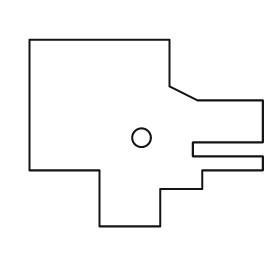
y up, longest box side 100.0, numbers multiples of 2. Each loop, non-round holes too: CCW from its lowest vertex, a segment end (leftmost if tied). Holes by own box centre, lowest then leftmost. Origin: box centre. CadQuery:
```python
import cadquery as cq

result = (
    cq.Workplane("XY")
    .moveTo(-20.0, -40.0)
    .lineTo(6.0, -40.0)
    .lineTo(6.0, -24.0)
    .lineTo(24.0, -24.0)
    .lineTo(24.0, -16.0)
    .lineTo(50.0, -16.0)
    .lineTo(50.0, -10.0)
    .lineTo(20.0, -10.0)
    .lineTo(20.0, -4.0)
    .lineTo(50.0, -4.0)
    .lineTo(50.0, 14.0)
    .lineTo(22.0, 14.0)
    .lineTo(10.0, 20.0)
    .lineTo(10.0, 40.0)
    .lineTo(-50.0, 40.0)
    .lineTo(-50.0, -16.0)
    .lineTo(-20.0, -16.0)
    .close()
    .moveTo(-2.0, -2.0)
    .circle(4.0)
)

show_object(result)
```